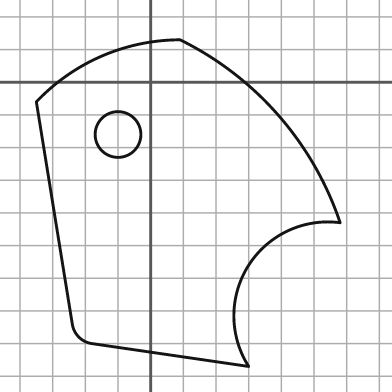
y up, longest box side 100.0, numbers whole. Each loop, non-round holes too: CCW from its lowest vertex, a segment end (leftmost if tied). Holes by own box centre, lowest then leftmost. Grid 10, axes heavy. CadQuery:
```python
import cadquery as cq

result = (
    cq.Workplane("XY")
    .moveTo(30.0, -87.0)
    .threePointArc((30.0, -56.0), (58.0, -43.0))
    .threePointArc((39.0, -10.0), (9.0, 13.0))
    .threePointArc((-15.0, 8.0), (-35.0, -6.0))
    .lineTo(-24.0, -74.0)
    .threePointArc((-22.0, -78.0), (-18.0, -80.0))
    .close()
    .moveTo(-10.0, -16.0)
    .circle(7.0)
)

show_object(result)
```